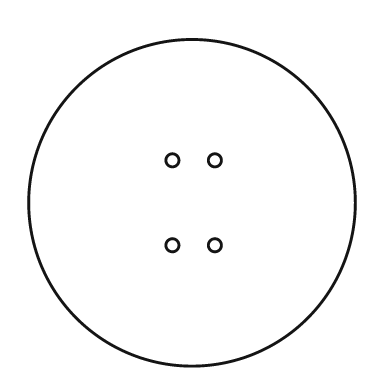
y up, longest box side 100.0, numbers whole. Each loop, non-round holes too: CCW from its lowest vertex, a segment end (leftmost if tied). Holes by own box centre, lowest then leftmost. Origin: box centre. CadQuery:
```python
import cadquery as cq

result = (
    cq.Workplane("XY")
    .moveTo(0.0, 0.0)
    .circle(50.0)
    .moveTo(-6.0, -13.0)
    .circle(2.0)
    .moveTo(7.0, -13.0)
    .circle(2.0)
    .moveTo(-6.0, 13.0)
    .circle(2.0)
    .moveTo(7.0, 13.0)
    .circle(2.0)
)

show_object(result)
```